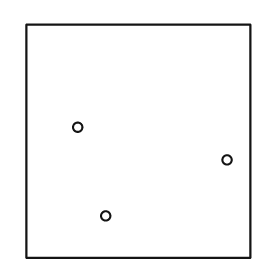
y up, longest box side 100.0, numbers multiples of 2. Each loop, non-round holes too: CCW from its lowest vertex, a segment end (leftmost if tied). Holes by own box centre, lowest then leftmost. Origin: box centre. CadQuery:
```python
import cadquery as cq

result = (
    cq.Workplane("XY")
    .moveTo(-48.0, -50.0)
    .lineTo(48.0, -50.0)
    .lineTo(48.0, 50.0)
    .lineTo(-48.0, 50.0)
    .close()
    .moveTo(-14.0, -32.0)
    .circle(2.0)
    .moveTo(38.0, -8.0)
    .circle(2.0)
    .moveTo(-26.0, 6.0)
    .circle(2.0)
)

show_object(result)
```